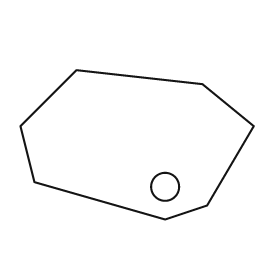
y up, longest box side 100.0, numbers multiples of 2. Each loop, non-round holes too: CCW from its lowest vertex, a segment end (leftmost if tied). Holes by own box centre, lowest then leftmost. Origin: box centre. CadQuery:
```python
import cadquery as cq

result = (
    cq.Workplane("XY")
    .moveTo(12.0, -32.0)
    .lineTo(30.0, -26.0)
    .lineTo(50.0, 8.0)
    .lineTo(28.0, 26.0)
    .lineTo(-26.0, 32.0)
    .lineTo(-50.0, 8.0)
    .lineTo(-44.0, -16.0)
    .close()
    .moveTo(12.0, -18.0)
    .circle(6.0)
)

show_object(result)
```